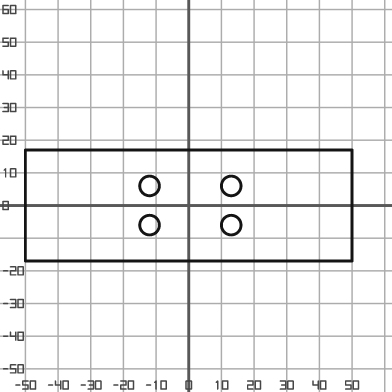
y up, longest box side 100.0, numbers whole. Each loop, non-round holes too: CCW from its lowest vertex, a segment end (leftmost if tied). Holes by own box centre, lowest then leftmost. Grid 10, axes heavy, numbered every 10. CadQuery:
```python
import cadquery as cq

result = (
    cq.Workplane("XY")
    .moveTo(-50.0, -17.0)
    .lineTo(50.0, -17.0)
    .lineTo(50.0, 17.0)
    .lineTo(-50.0, 17.0)
    .close()
    .moveTo(-12.0, -6.0)
    .circle(3.0)
    .moveTo(13.0, -6.0)
    .circle(3.0)
    .moveTo(-12.0, 6.0)
    .circle(3.0)
    .moveTo(13.0, 6.0)
    .circle(3.0)
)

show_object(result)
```